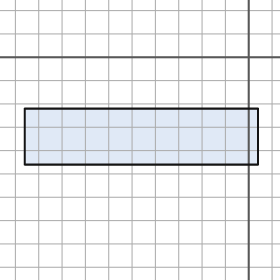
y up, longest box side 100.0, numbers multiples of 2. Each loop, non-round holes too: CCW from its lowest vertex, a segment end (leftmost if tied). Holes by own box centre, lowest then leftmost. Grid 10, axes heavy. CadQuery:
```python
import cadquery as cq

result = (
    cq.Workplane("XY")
    .moveTo(-96.0, -46.0)
    .lineTo(4.0, -46.0)
    .lineTo(4.0, -22.0)
    .lineTo(-96.0, -22.0)
    .close()
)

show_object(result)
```